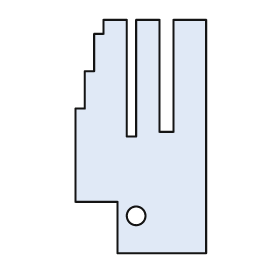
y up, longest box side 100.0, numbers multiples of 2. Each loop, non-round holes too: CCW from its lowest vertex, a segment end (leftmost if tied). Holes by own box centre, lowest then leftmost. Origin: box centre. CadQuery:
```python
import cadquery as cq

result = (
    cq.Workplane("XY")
    .moveTo(-10.0, -50.0)
    .lineTo(28.0, -50.0)
    .lineTo(28.0, 50.0)
    .lineTo(14.0, 50.0)
    .lineTo(14.0, 2.0)
    .lineTo(8.0, 2.0)
    .lineTo(8.0, 50.0)
    .lineTo(-2.0, 50.0)
    .lineTo(-2.0, 0.0)
    .lineTo(-6.0, 0.0)
    .lineTo(-6.0, 50.0)
    .lineTo(-16.0, 50.0)
    .lineTo(-16.0, 44.0)
    .lineTo(-20.0, 44.0)
    .lineTo(-20.0, 28.0)
    .lineTo(-24.0, 28.0)
    .lineTo(-24.0, 12.0)
    .lineTo(-28.0, 12.0)
    .lineTo(-28.0, -28.0)
    .lineTo(-10.0, -28.0)
    .close()
    .moveTo(-2.0, -34.0)
    .circle(4.0)
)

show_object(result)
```